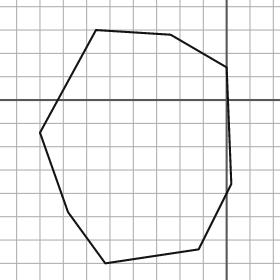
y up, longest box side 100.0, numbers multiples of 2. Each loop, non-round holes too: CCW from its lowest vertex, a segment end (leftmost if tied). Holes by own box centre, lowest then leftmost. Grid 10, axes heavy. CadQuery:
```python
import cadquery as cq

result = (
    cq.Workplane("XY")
    .moveTo(-52.0, -70.0)
    .lineTo(-12.0, -64.0)
    .lineTo(2.0, -36.0)
    .lineTo(0.0, 14.0)
    .lineTo(-24.0, 28.0)
    .lineTo(-56.0, 30.0)
    .lineTo(-80.0, -14.0)
    .lineTo(-68.0, -48.0)
    .close()
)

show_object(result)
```